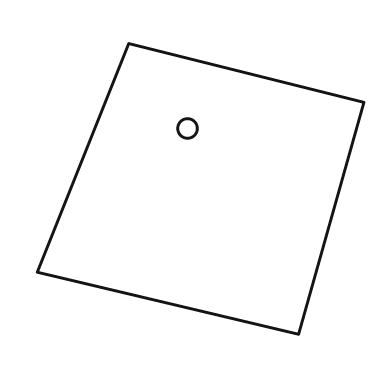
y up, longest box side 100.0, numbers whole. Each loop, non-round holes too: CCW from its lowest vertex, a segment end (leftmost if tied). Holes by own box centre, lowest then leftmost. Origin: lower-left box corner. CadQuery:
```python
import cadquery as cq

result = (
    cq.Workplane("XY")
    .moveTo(80.0, 0.0)
    .lineTo(100.0, 71.0)
    .lineTo(28.0, 89.0)
    .lineTo(0.0, 19.0)
    .close()
    .moveTo(46.0, 63.0)
    .circle(3.0)
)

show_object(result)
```